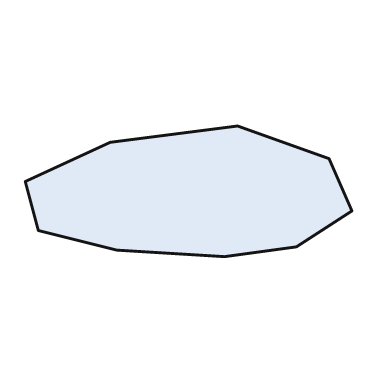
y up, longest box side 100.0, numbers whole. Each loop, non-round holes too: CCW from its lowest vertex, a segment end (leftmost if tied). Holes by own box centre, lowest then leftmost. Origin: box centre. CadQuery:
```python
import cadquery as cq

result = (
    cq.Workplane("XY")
    .moveTo(11.0, -20.0)
    .lineTo(33.0, -17.0)
    .lineTo(50.0, -6.0)
    .lineTo(43.0, 10.0)
    .lineTo(15.0, 20.0)
    .lineTo(-24.0, 15.0)
    .lineTo(-50.0, 3.0)
    .lineTo(-46.0, -12.0)
    .lineTo(-22.0, -18.0)
    .close()
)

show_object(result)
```